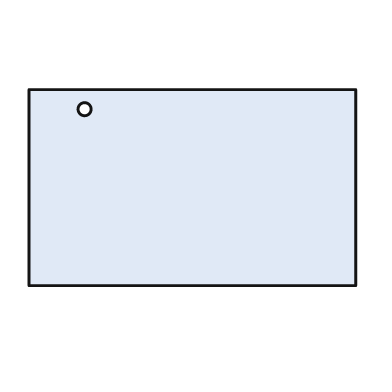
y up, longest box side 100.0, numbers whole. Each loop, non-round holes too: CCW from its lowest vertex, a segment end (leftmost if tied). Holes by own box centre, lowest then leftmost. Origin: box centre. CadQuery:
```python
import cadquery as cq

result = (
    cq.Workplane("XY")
    .moveTo(-50.0, -30.0)
    .lineTo(50.0, -30.0)
    .lineTo(50.0, 30.0)
    .lineTo(-50.0, 30.0)
    .close()
    .moveTo(-33.0, 24.0)
    .circle(2.0)
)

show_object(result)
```